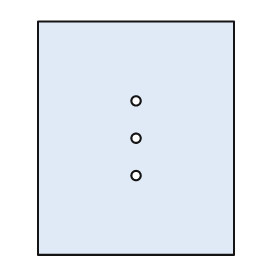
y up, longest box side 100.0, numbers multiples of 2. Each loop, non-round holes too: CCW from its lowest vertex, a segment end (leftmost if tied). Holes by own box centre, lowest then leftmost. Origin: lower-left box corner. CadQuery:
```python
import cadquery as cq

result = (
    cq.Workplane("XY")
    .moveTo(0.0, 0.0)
    .lineTo(84.0, 0.0)
    .lineTo(84.0, 100.0)
    .lineTo(0.0, 100.0)
    .close()
    .moveTo(42.0, 34.0)
    .circle(2.0)
    .moveTo(42.0, 50.0)
    .circle(2.0)
    .moveTo(42.0, 66.0)
    .circle(2.0)
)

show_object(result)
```